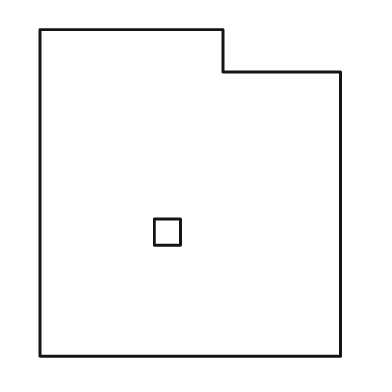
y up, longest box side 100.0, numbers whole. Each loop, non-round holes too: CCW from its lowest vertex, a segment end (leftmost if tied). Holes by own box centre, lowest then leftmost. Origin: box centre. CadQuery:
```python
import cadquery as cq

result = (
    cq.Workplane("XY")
    .moveTo(-46.0, -50.0)
    .lineTo(46.0, -50.0)
    .lineTo(46.0, 37.0)
    .lineTo(10.0, 37.0)
    .lineTo(10.0, 50.0)
    .lineTo(-46.0, 50.0)
    .close()
    .moveTo(-11.0, -16.0)
    .lineTo(-3.0, -16.0)
    .lineTo(-3.0, -8.0)
    .lineTo(-11.0, -8.0)
    .close()
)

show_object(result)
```